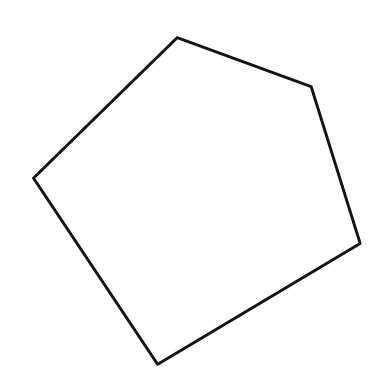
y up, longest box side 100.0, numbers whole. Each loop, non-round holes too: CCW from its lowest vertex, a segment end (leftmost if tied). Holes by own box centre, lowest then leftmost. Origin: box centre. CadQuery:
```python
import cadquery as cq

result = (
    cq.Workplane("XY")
    .moveTo(-12.0, -50.0)
    .lineTo(50.0, -13.0)
    .lineTo(35.0, 35.0)
    .lineTo(-6.0, 50.0)
    .lineTo(-50.0, 7.0)
    .close()
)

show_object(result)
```